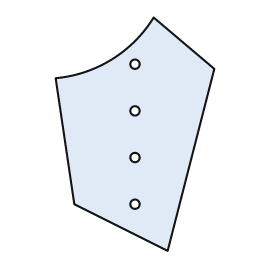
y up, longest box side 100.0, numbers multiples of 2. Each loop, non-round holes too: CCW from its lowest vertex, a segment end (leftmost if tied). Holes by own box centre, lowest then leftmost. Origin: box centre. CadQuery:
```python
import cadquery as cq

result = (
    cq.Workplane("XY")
    .moveTo(14.0, -50.0)
    .lineTo(34.0, 28.0)
    .lineTo(8.0, 50.0)
    .threePointArc((-10.0, 32.0), (-34.0, 24.0))
    .lineTo(-26.0, -30.0)
    .close()
    .moveTo(0.0, -30.0)
    .circle(2.0)
    .moveTo(0.0, -10.0)
    .circle(2.0)
    .moveTo(0.0, 10.0)
    .circle(2.0)
    .moveTo(0.0, 30.0)
    .circle(2.0)
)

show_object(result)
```